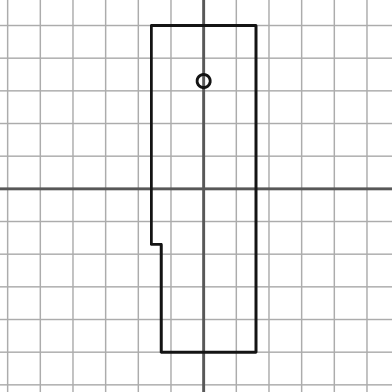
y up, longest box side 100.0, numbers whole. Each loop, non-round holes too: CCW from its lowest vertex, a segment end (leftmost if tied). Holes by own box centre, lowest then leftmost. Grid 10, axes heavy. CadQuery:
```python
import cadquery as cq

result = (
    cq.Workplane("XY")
    .moveTo(-13.0, -50.0)
    .lineTo(16.0, -50.0)
    .lineTo(16.0, 50.0)
    .lineTo(-16.0, 50.0)
    .lineTo(-16.0, -17.0)
    .lineTo(-13.0, -17.0)
    .close()
    .moveTo(0.0, 33.0)
    .circle(2.0)
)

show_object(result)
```